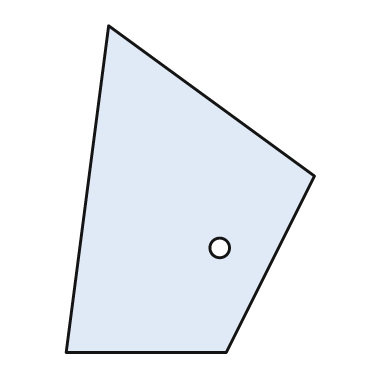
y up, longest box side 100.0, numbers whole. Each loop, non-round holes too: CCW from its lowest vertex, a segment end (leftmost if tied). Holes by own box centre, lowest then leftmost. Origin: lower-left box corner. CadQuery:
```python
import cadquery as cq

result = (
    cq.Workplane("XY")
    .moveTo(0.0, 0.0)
    .lineTo(49.0, 0.0)
    .lineTo(76.0, 54.0)
    .lineTo(13.0, 100.0)
    .close()
    .moveTo(47.0, 32.0)
    .circle(3.0)
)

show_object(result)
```